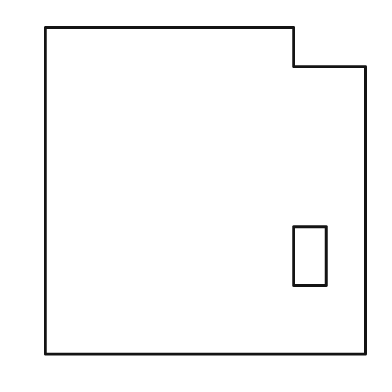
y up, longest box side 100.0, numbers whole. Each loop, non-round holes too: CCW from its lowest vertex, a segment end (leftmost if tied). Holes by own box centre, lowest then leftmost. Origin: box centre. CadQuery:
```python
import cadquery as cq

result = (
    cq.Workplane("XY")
    .moveTo(-49.0, -50.0)
    .lineTo(49.0, -50.0)
    .lineTo(49.0, 38.0)
    .lineTo(27.0, 38.0)
    .lineTo(27.0, 50.0)
    .lineTo(-49.0, 50.0)
    .close()
    .moveTo(27.0, -29.0)
    .lineTo(37.0, -29.0)
    .lineTo(37.0, -11.0)
    .lineTo(27.0, -11.0)
    .close()
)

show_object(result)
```